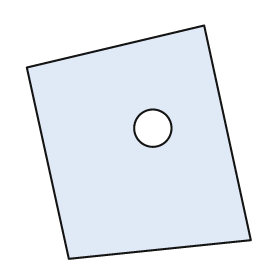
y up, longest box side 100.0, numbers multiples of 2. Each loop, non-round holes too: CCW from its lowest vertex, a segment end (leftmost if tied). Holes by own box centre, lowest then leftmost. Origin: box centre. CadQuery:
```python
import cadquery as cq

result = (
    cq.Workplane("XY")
    .moveTo(-30.0, -50.0)
    .lineTo(48.0, -42.0)
    .lineTo(28.0, 50.0)
    .lineTo(-48.0, 32.0)
    .close()
    .moveTo(6.0, 6.0)
    .circle(8.0)
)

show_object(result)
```